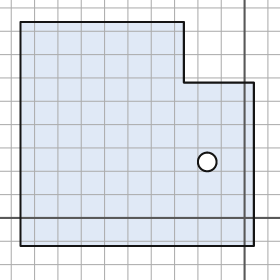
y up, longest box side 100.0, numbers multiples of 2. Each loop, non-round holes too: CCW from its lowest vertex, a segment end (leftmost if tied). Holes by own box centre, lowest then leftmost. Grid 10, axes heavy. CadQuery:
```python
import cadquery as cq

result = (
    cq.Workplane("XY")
    .moveTo(-96.0, -12.0)
    .lineTo(4.0, -12.0)
    .lineTo(4.0, 58.0)
    .lineTo(-26.0, 58.0)
    .lineTo(-26.0, 84.0)
    .lineTo(-96.0, 84.0)
    .close()
    .moveTo(-16.0, 24.0)
    .circle(4.0)
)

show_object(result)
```